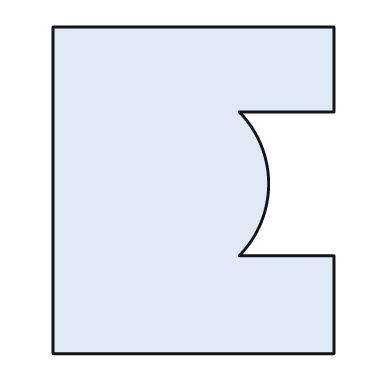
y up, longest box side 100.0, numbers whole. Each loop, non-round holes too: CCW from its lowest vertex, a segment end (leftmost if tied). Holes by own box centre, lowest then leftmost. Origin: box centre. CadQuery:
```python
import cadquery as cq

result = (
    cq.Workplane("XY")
    .moveTo(-43.0, -50.0)
    .lineTo(43.0, -50.0)
    .lineTo(43.0, -20.0)
    .lineTo(14.0, -20.0)
    .threePointArc((23.0, 2.0), (14.0, 24.0))
    .lineTo(43.0, 24.0)
    .lineTo(43.0, 50.0)
    .lineTo(-43.0, 50.0)
    .close()
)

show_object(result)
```